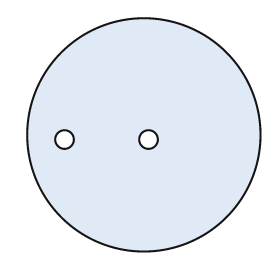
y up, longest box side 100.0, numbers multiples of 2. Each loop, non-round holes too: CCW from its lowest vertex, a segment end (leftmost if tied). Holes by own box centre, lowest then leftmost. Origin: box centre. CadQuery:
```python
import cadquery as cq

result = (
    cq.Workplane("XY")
    .moveTo(0.0, 0.0)
    .circle(50.0)
    .moveTo(-34.0, -2.0)
    .circle(4.0)
    .moveTo(2.0, -2.0)
    .circle(4.0)
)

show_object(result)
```